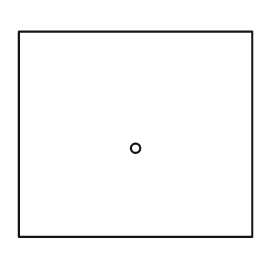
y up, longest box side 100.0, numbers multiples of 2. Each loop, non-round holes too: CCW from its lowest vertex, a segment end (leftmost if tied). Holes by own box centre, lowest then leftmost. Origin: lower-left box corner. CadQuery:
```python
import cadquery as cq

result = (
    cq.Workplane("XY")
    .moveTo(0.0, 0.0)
    .lineTo(100.0, 0.0)
    .lineTo(100.0, 88.0)
    .lineTo(0.0, 88.0)
    .close()
    .moveTo(50.0, 38.0)
    .circle(2.0)
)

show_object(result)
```